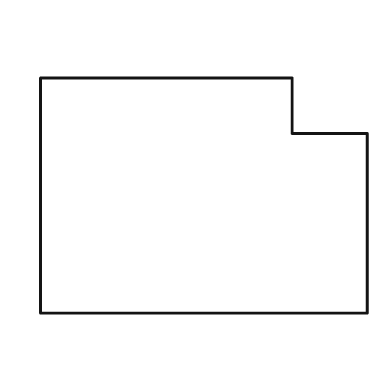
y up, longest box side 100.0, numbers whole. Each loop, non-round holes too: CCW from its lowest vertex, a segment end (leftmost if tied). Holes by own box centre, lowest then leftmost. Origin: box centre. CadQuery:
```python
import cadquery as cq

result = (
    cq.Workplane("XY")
    .moveTo(-50.0, -36.0)
    .lineTo(50.0, -36.0)
    .lineTo(50.0, 19.0)
    .lineTo(27.0, 19.0)
    .lineTo(27.0, 36.0)
    .lineTo(-50.0, 36.0)
    .close()
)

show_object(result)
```